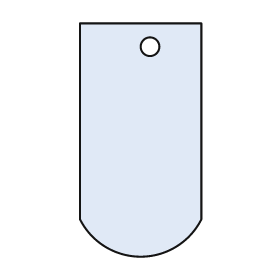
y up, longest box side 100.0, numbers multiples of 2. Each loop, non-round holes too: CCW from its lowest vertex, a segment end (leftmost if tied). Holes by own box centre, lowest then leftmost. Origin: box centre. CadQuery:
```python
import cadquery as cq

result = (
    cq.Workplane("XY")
    .moveTo(-26.0, -34.0)
    .threePointArc((0.0, -50.0), (26.0, -34.0))
    .lineTo(26.0, 50.0)
    .lineTo(-26.0, 50.0)
    .close()
    .moveTo(4.0, 40.0)
    .circle(4.0)
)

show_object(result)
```